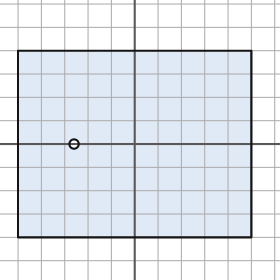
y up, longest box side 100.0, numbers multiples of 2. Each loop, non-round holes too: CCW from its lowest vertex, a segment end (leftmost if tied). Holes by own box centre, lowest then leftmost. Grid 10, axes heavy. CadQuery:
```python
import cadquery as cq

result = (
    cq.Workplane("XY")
    .moveTo(-50.0, -40.0)
    .lineTo(50.0, -40.0)
    .lineTo(50.0, 40.0)
    .lineTo(-50.0, 40.0)
    .close()
    .moveTo(-26.0, 0.0)
    .circle(2.0)
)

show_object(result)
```